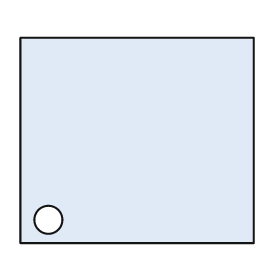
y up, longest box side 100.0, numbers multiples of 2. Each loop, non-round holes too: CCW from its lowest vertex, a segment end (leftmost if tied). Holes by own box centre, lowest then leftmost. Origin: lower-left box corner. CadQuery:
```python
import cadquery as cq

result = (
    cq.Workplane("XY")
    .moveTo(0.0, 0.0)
    .lineTo(100.0, 0.0)
    .lineTo(100.0, 88.0)
    .lineTo(0.0, 88.0)
    .close()
    .moveTo(12.0, 10.0)
    .circle(6.0)
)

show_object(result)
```